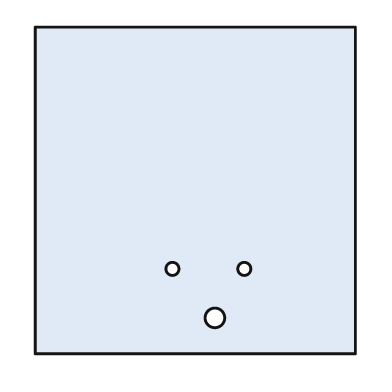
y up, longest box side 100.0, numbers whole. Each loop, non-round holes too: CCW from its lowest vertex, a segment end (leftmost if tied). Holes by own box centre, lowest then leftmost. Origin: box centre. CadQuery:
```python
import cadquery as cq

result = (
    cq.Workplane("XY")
    .moveTo(-49.0, -50.0)
    .lineTo(49.0, -50.0)
    .lineTo(49.0, 50.0)
    .lineTo(-49.0, 50.0)
    .close()
    .moveTo(6.0, -39.0)
    .circle(3.0)
    .moveTo(-7.0, -24.0)
    .circle(2.0)
    .moveTo(15.0, -24.0)
    .circle(2.0)
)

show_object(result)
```